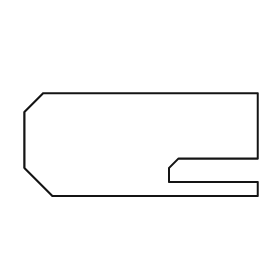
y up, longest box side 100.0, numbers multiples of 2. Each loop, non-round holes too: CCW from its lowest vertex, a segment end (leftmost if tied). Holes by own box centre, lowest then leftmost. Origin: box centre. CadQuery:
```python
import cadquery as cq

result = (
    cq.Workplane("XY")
    .moveTo(-38.0, -22.0)
    .lineTo(50.0, -22.0)
    .lineTo(50.0, -16.0)
    .lineTo(12.0, -16.0)
    .lineTo(12.0, -10.0)
    .lineTo(16.0, -6.0)
    .lineTo(50.0, -6.0)
    .lineTo(50.0, 22.0)
    .lineTo(-42.0, 22.0)
    .lineTo(-50.0, 14.0)
    .lineTo(-50.0, -10.0)
    .close()
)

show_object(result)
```